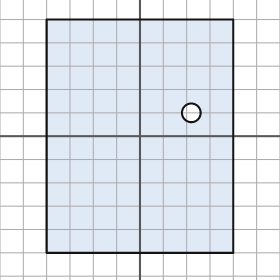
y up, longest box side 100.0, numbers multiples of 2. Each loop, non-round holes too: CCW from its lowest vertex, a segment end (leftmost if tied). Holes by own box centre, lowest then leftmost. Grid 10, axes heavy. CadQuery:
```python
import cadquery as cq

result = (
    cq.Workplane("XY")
    .moveTo(-40.0, -50.0)
    .lineTo(40.0, -50.0)
    .lineTo(40.0, 50.0)
    .lineTo(-40.0, 50.0)
    .close()
    .moveTo(22.0, 10.0)
    .circle(4.0)
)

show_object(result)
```